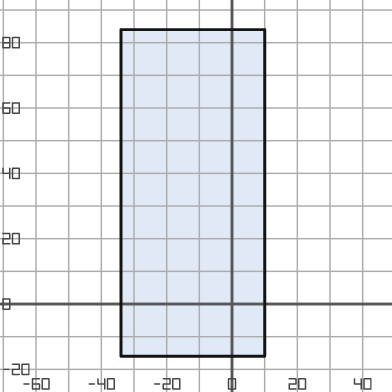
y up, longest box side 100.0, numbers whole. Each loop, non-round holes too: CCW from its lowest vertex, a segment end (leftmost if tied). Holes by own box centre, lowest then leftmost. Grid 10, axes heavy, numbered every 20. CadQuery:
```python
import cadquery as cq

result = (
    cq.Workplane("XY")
    .moveTo(-34.0, -16.0)
    .lineTo(10.0, -16.0)
    .lineTo(10.0, 84.0)
    .lineTo(-34.0, 84.0)
    .close()
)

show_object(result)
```